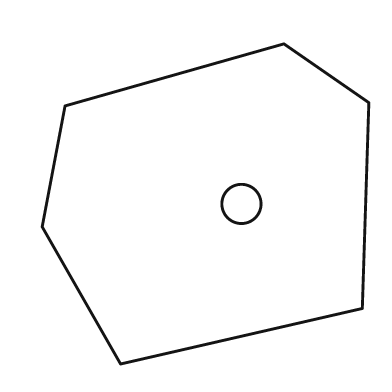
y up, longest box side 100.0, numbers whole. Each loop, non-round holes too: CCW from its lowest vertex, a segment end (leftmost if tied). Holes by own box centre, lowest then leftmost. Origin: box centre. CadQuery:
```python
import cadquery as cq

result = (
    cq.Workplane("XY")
    .moveTo(-26.0, -49.0)
    .lineTo(48.0, -32.0)
    .lineTo(50.0, 31.0)
    .lineTo(24.0, 49.0)
    .lineTo(-43.0, 30.0)
    .lineTo(-50.0, -7.0)
    .close()
    .moveTo(11.0, 0.0)
    .circle(6.0)
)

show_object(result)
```